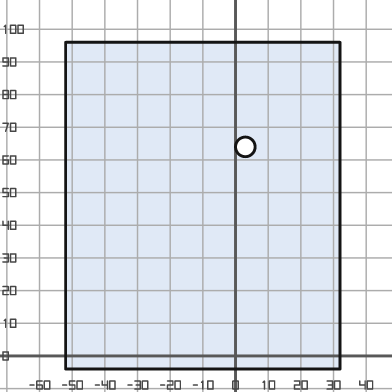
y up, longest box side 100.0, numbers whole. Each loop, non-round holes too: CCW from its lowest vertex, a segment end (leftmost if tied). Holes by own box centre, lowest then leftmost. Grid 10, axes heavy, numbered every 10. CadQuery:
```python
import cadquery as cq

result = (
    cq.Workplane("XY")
    .moveTo(-52.0, -4.0)
    .lineTo(32.0, -4.0)
    .lineTo(32.0, 96.0)
    .lineTo(-52.0, 96.0)
    .close()
    .moveTo(3.0, 64.0)
    .circle(3.0)
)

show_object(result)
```